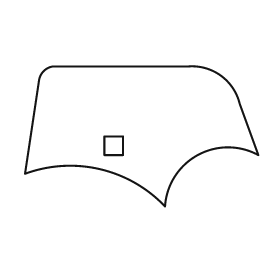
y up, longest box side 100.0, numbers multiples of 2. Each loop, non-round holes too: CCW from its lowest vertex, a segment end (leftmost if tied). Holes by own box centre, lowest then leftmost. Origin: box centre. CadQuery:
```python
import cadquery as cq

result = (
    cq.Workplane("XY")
    .moveTo(10.0, -30.0)
    .threePointArc((24.0, -8.0), (50.0, -8.0))
    .lineTo(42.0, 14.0)
    .threePointArc((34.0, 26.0), (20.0, 30.0))
    .lineTo(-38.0, 30.0)
    .threePointArc((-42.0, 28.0), (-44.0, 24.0))
    .lineTo(-50.0, -16.0)
    .threePointArc((-18.0, -14.0), (10.0, -30.0))
    .close()
    .moveTo(-16.0, -8.0)
    .lineTo(-8.0, -8.0)
    .lineTo(-8.0, 0.0)
    .lineTo(-16.0, 0.0)
    .close()
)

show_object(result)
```